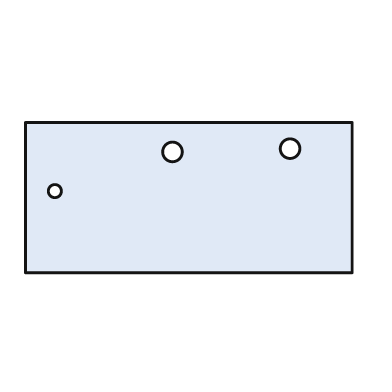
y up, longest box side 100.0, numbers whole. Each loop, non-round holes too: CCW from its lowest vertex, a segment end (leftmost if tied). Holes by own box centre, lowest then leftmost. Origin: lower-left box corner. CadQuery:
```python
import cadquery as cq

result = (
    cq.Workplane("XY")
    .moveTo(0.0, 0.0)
    .lineTo(100.0, 0.0)
    .lineTo(100.0, 46.0)
    .lineTo(0.0, 46.0)
    .close()
    .moveTo(9.0, 25.0)
    .circle(2.0)
    .moveTo(45.0, 37.0)
    .circle(3.0)
    .moveTo(81.0, 38.0)
    .circle(3.0)
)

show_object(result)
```